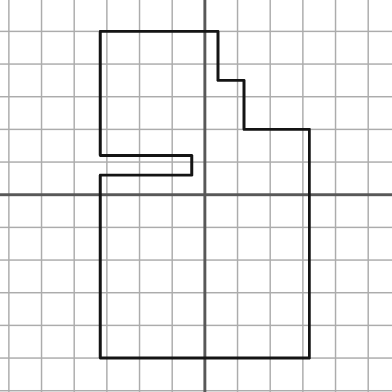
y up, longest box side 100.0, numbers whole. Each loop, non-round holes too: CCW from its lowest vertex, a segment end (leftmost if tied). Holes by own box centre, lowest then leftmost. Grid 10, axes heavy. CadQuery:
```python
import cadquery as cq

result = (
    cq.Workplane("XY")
    .moveTo(-32.0, -50.0)
    .lineTo(32.0, -50.0)
    .lineTo(32.0, 20.0)
    .lineTo(12.0, 20.0)
    .lineTo(12.0, 35.0)
    .lineTo(4.0, 35.0)
    .lineTo(4.0, 50.0)
    .lineTo(-32.0, 50.0)
    .lineTo(-32.0, 12.0)
    .lineTo(-4.0, 12.0)
    .lineTo(-4.0, 6.0)
    .lineTo(-32.0, 6.0)
    .close()
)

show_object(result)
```